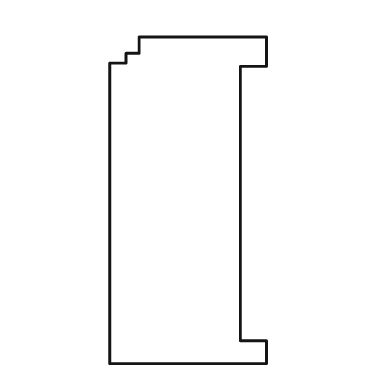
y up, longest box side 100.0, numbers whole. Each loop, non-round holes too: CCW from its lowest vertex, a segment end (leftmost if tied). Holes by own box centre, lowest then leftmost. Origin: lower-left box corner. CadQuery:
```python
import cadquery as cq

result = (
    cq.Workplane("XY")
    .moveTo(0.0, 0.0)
    .lineTo(48.0, 0.0)
    .lineTo(48.0, 7.0)
    .lineTo(40.0, 7.0)
    .lineTo(40.0, 91.0)
    .lineTo(48.0, 91.0)
    .lineTo(48.0, 100.0)
    .lineTo(9.0, 100.0)
    .lineTo(9.0, 95.0)
    .lineTo(5.0, 95.0)
    .lineTo(5.0, 92.0)
    .lineTo(0.0, 92.0)
    .close()
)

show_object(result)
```